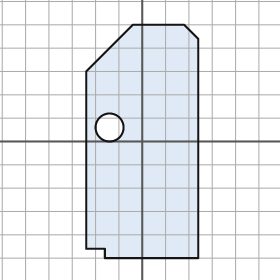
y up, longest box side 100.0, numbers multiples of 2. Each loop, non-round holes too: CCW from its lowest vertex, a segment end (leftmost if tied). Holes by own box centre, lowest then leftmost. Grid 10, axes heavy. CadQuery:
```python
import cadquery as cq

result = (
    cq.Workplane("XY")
    .moveTo(-16.0, -50.0)
    .lineTo(24.0, -50.0)
    .lineTo(24.0, 44.0)
    .lineTo(18.0, 50.0)
    .lineTo(-4.0, 50.0)
    .lineTo(-24.0, 30.0)
    .lineTo(-24.0, -46.0)
    .lineTo(-16.0, -46.0)
    .close()
    .moveTo(-14.0, 6.0)
    .circle(6.0)
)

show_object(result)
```